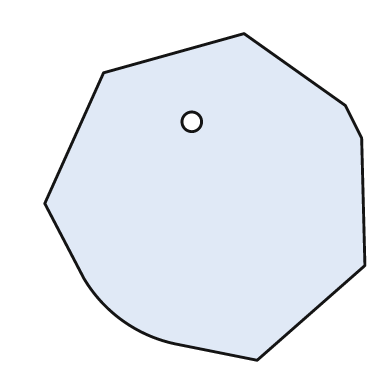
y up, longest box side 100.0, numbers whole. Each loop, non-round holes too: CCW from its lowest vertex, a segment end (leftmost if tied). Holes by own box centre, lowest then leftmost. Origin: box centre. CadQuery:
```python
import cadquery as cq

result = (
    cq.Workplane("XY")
    .moveTo(16.0, -50.0)
    .lineTo(49.0, -21.0)
    .lineTo(48.0, 18.0)
    .lineTo(43.0, 28.0)
    .lineTo(12.0, 50.0)
    .lineTo(-31.0, 38.0)
    .lineTo(-49.0, -2.0)
    .lineTo(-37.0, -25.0)
    .threePointArc((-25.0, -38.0), (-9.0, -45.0))
    .close()
    .moveTo(-4.0, 23.0)
    .circle(3.0)
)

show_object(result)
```